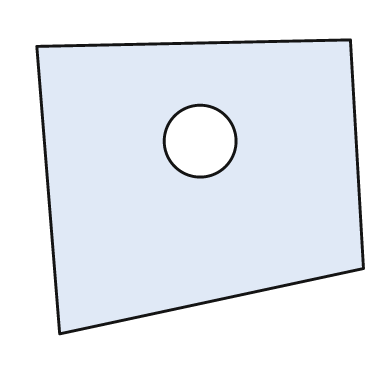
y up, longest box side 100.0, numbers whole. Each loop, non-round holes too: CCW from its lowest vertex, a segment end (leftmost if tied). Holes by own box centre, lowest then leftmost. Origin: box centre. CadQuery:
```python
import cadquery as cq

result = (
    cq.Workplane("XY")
    .moveTo(-43.0, -45.0)
    .lineTo(50.0, -25.0)
    .lineTo(46.0, 45.0)
    .lineTo(-50.0, 43.0)
    .close()
    .moveTo(0.0, 14.0)
    .circle(11.0)
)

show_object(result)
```